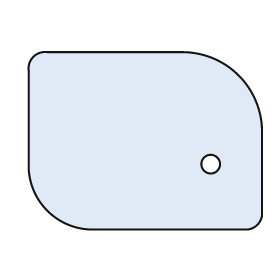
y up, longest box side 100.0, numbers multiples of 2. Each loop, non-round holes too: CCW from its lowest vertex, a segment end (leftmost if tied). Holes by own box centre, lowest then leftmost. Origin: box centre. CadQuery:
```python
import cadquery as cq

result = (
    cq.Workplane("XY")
    .moveTo(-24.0, -38.0)
    .lineTo(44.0, -38.0)
    .threePointArc((48.0, -36.0), (50.0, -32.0))
    .lineTo(50.0, 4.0)
    .threePointArc((40.0, 28.0), (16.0, 38.0))
    .lineTo(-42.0, 38.0)
    .threePointArc((-48.0, 36.0), (-50.0, 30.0))
    .lineTo(-50.0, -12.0)
    .threePointArc((-42.0, -30.0), (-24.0, -38.0))
    .close()
    .moveTo(28.0, -10.0)
    .circle(4.0)
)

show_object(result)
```